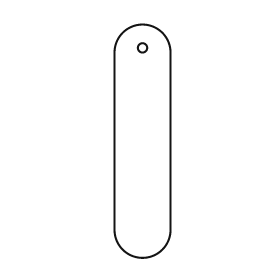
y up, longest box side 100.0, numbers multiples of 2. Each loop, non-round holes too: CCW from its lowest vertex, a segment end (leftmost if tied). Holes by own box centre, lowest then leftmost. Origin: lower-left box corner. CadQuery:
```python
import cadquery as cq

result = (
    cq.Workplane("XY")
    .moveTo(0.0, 12.0)
    .threePointArc((12.0, 0.0), (24.0, 12.0))
    .lineTo(24.0, 88.0)
    .threePointArc((12.0, 100.0), (0.0, 88.0))
    .close()
    .moveTo(12.0, 90.0)
    .circle(2.0)
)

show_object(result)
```